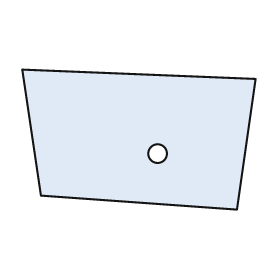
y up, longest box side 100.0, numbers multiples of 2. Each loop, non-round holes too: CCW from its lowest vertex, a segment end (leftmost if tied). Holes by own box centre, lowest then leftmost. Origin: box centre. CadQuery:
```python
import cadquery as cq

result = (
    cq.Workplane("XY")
    .moveTo(42.0, -30.0)
    .lineTo(50.0, 26.0)
    .lineTo(-50.0, 30.0)
    .lineTo(-42.0, -24.0)
    .close()
    .moveTo(8.0, -6.0)
    .circle(4.0)
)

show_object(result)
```